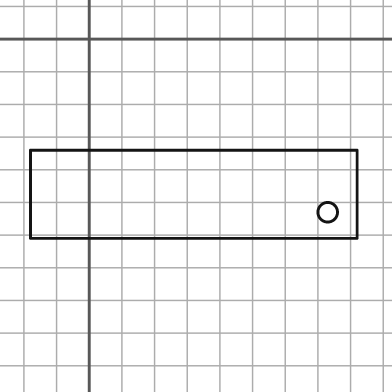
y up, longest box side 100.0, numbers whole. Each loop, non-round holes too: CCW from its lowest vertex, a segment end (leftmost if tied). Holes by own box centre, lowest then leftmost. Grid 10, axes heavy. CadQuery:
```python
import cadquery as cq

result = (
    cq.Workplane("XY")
    .moveTo(-18.0, -61.0)
    .lineTo(82.0, -61.0)
    .lineTo(82.0, -34.0)
    .lineTo(-18.0, -34.0)
    .close()
    .moveTo(73.0, -53.0)
    .circle(3.0)
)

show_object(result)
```